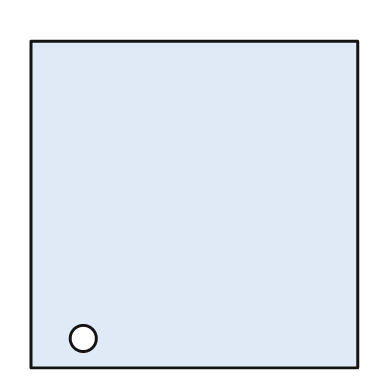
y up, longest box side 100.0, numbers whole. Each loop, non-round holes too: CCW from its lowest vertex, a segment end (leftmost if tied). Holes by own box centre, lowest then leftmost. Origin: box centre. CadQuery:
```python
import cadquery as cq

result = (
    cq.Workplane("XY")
    .moveTo(-50.0, -50.0)
    .lineTo(50.0, -50.0)
    .lineTo(50.0, 50.0)
    .lineTo(-50.0, 50.0)
    .close()
    .moveTo(-34.0, -41.0)
    .circle(4.0)
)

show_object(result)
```